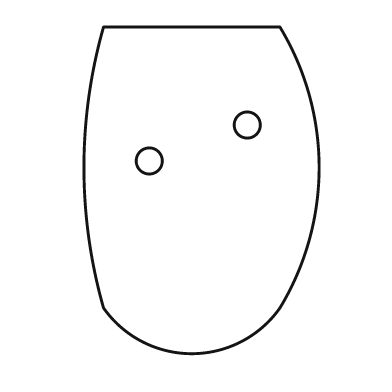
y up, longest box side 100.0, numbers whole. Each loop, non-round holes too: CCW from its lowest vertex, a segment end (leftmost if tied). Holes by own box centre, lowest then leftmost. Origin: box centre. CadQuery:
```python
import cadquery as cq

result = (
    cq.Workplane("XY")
    .moveTo(-30.0, -36.0)
    .threePointArc((-3.0, -50.0), (24.0, -36.0))
    .threePointArc((36.0, 7.0), (24.0, 50.0))
    .lineTo(-30.0, 50.0)
    .threePointArc((-36.0, 7.0), (-30.0, -36.0))
    .close()
    .moveTo(-16.0, 9.0)
    .circle(4.0)
    .moveTo(14.0, 20.0)
    .circle(4.0)
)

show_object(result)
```